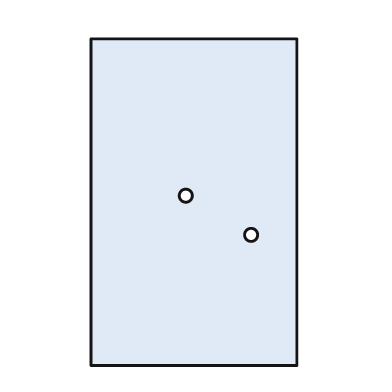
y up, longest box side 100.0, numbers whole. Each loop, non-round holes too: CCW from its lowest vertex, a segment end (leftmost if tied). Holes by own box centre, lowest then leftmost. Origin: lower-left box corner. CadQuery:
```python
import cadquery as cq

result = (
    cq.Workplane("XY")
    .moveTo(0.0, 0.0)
    .lineTo(63.0, 0.0)
    .lineTo(63.0, 100.0)
    .lineTo(0.0, 100.0)
    .close()
    .moveTo(49.0, 40.0)
    .circle(2.0)
    .moveTo(29.0, 52.0)
    .circle(2.0)
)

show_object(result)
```